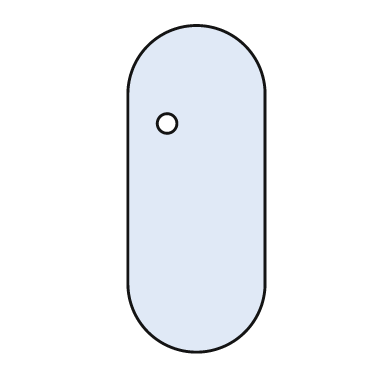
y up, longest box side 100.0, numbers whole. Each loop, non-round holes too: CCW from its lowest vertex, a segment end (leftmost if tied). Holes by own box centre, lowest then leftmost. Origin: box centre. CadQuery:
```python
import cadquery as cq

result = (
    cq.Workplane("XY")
    .moveTo(-21.0, -29.0)
    .threePointArc((0.0, -50.0), (21.0, -29.0))
    .lineTo(21.0, 29.0)
    .threePointArc((0.0, 50.0), (-21.0, 29.0))
    .close()
    .moveTo(-9.0, 20.0)
    .circle(3.0)
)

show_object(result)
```